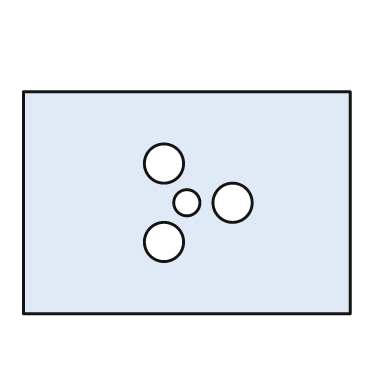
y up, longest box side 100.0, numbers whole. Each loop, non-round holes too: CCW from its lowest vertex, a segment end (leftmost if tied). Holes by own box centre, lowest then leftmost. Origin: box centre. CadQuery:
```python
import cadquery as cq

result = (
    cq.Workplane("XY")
    .moveTo(-50.0, -34.0)
    .lineTo(50.0, -34.0)
    .lineTo(50.0, 34.0)
    .lineTo(-50.0, 34.0)
    .close()
    .moveTo(-7.0, -12.0)
    .circle(6.0)
    .moveTo(0.0, 0.0)
    .circle(4.0)
    .moveTo(14.0, 0.0)
    .circle(6.0)
    .moveTo(-7.0, 12.0)
    .circle(6.0)
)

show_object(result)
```